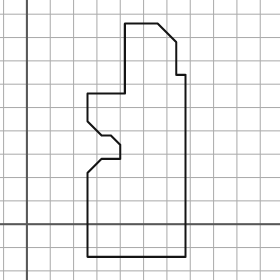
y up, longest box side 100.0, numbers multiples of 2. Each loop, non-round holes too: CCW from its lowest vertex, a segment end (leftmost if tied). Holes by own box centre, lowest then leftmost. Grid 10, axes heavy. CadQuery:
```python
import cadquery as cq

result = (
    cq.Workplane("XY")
    .moveTo(26.0, -14.0)
    .lineTo(68.0, -14.0)
    .lineTo(68.0, 64.0)
    .lineTo(64.0, 64.0)
    .lineTo(64.0, 78.0)
    .lineTo(56.0, 86.0)
    .lineTo(42.0, 86.0)
    .lineTo(42.0, 56.0)
    .lineTo(26.0, 56.0)
    .lineTo(26.0, 44.0)
    .lineTo(32.0, 38.0)
    .lineTo(36.0, 38.0)
    .lineTo(40.0, 34.0)
    .lineTo(40.0, 28.0)
    .lineTo(32.0, 28.0)
    .lineTo(26.0, 22.0)
    .close()
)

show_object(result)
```